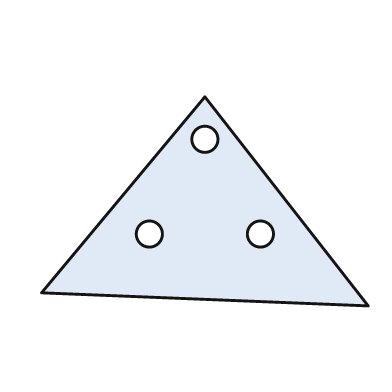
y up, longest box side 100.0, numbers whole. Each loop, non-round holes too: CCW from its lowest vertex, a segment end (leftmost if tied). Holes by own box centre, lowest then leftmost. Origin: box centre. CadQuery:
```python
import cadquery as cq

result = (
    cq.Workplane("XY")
    .moveTo(50.0, -32.0)
    .lineTo(0.0, 32.0)
    .lineTo(-50.0, -28.0)
    .close()
    .moveTo(-17.0, -10.0)
    .circle(4.0)
    .moveTo(17.0, -10.0)
    .circle(4.0)
    .moveTo(0.0, 19.0)
    .circle(4.0)
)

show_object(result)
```